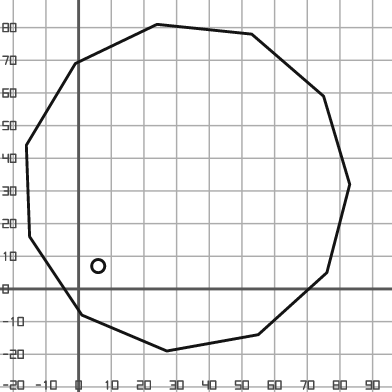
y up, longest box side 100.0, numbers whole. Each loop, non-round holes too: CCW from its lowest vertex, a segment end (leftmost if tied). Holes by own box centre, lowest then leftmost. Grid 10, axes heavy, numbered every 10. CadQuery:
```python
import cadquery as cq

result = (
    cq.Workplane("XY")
    .moveTo(27.0, -19.0)
    .lineTo(55.0, -14.0)
    .lineTo(76.0, 5.0)
    .lineTo(83.0, 32.0)
    .lineTo(75.0, 59.0)
    .lineTo(53.0, 78.0)
    .lineTo(24.0, 81.0)
    .lineTo(-1.0, 69.0)
    .lineTo(-16.0, 44.0)
    .lineTo(-15.0, 16.0)
    .lineTo(1.0, -8.0)
    .close()
    .moveTo(6.0, 7.0)
    .circle(2.0)
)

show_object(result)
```